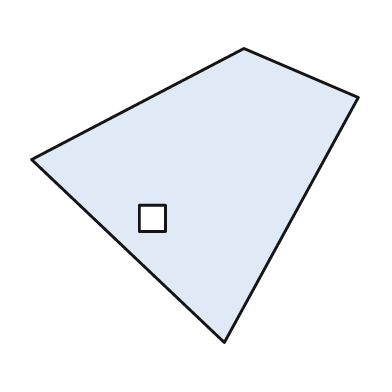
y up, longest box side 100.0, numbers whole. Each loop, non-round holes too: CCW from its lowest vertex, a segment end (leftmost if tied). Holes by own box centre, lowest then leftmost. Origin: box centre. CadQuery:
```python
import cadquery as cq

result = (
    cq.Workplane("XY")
    .moveTo(9.0, -45.0)
    .lineTo(50.0, 30.0)
    .lineTo(15.0, 45.0)
    .lineTo(-50.0, 11.0)
    .close()
    .moveTo(-17.0, -11.0)
    .lineTo(-9.0, -11.0)
    .lineTo(-9.0, -3.0)
    .lineTo(-17.0, -3.0)
    .close()
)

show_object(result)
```